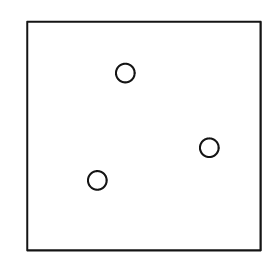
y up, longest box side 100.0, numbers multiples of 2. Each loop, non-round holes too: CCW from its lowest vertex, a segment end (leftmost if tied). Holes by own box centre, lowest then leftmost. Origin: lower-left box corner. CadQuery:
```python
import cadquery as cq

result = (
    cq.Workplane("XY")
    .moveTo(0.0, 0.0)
    .lineTo(100.0, 0.0)
    .lineTo(100.0, 98.0)
    .lineTo(0.0, 98.0)
    .close()
    .moveTo(30.0, 30.0)
    .circle(4.0)
    .moveTo(78.0, 44.0)
    .circle(4.0)
    .moveTo(42.0, 76.0)
    .circle(4.0)
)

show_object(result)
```